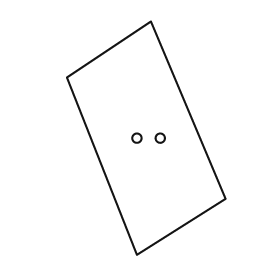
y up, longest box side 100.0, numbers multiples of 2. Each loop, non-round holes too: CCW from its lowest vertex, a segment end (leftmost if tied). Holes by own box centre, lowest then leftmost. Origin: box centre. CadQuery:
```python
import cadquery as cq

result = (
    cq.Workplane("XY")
    .moveTo(-4.0, -50.0)
    .lineTo(34.0, -26.0)
    .lineTo(2.0, 50.0)
    .lineTo(-34.0, 26.0)
    .close()
    .moveTo(-4.0, 0.0)
    .circle(2.0)
    .moveTo(6.0, 0.0)
    .circle(2.0)
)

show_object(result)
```